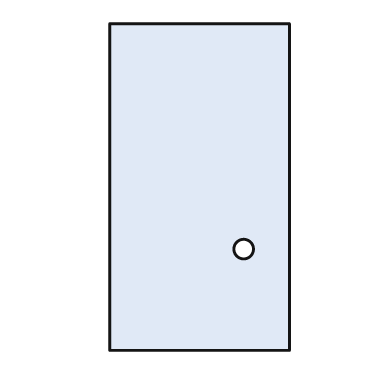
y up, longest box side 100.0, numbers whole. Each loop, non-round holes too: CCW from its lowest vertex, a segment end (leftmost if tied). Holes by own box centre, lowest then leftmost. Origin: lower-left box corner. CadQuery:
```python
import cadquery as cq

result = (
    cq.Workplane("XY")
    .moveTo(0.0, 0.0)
    .lineTo(55.0, 0.0)
    .lineTo(55.0, 100.0)
    .lineTo(0.0, 100.0)
    .close()
    .moveTo(41.0, 31.0)
    .circle(3.0)
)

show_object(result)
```